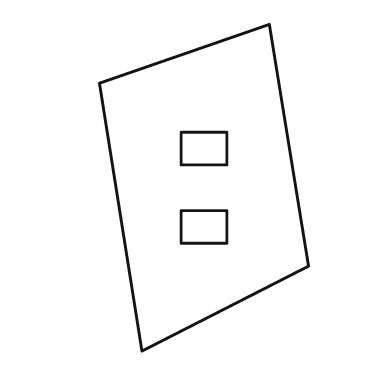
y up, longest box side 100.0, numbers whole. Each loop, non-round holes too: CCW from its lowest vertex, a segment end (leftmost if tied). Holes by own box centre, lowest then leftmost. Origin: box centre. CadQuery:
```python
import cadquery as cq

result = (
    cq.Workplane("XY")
    .moveTo(-19.0, -50.0)
    .lineTo(32.0, -24.0)
    .lineTo(20.0, 50.0)
    .lineTo(-32.0, 32.0)
    .close()
    .moveTo(-7.0, -17.0)
    .lineTo(7.0, -17.0)
    .lineTo(7.0, -7.0)
    .lineTo(-7.0, -7.0)
    .close()
    .moveTo(-7.0, 7.0)
    .lineTo(7.0, 7.0)
    .lineTo(7.0, 17.0)
    .lineTo(-7.0, 17.0)
    .close()
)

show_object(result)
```